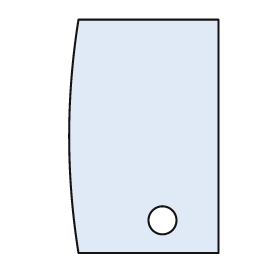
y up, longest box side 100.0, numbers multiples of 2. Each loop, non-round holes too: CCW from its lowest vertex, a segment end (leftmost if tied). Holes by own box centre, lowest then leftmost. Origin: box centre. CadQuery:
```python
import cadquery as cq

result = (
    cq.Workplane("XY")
    .moveTo(-28.0, -50.0)
    .lineTo(32.0, -50.0)
    .lineTo(32.0, 50.0)
    .lineTo(-28.0, 50.0)
    .threePointArc((-32.0, 0.0), (-28.0, -50.0))
    .close()
    .moveTo(8.0, -36.0)
    .circle(6.0)
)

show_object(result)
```